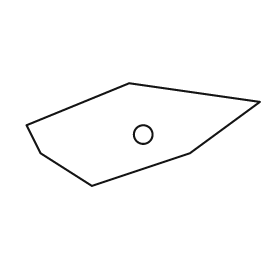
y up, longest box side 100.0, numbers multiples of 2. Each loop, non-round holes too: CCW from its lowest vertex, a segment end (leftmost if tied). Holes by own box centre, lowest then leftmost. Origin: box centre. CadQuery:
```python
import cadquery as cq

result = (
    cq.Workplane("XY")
    .moveTo(-22.0, -22.0)
    .lineTo(20.0, -8.0)
    .lineTo(50.0, 14.0)
    .lineTo(-6.0, 22.0)
    .lineTo(-50.0, 4.0)
    .lineTo(-44.0, -8.0)
    .close()
    .moveTo(0.0, 0.0)
    .circle(4.0)
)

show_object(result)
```